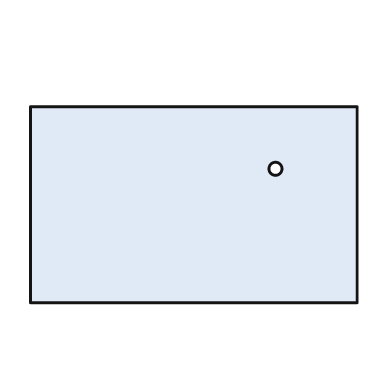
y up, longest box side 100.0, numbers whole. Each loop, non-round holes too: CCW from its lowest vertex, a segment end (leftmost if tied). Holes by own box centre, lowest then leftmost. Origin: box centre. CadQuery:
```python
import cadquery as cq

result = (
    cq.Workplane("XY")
    .moveTo(-50.0, -30.0)
    .lineTo(50.0, -30.0)
    .lineTo(50.0, 30.0)
    .lineTo(-50.0, 30.0)
    .close()
    .moveTo(25.0, 11.0)
    .circle(2.0)
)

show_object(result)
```